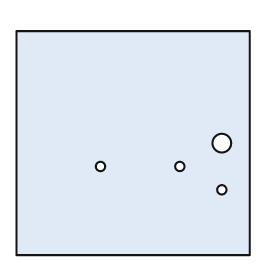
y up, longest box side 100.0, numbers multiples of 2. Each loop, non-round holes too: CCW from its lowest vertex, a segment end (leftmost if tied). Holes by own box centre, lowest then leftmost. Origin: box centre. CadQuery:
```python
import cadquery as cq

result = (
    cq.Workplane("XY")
    .moveTo(-50.0, -48.0)
    .lineTo(50.0, -48.0)
    .lineTo(50.0, 48.0)
    .lineTo(-50.0, 48.0)
    .close()
    .moveTo(38.0, -20.0)
    .circle(2.0)
    .moveTo(-14.0, -10.0)
    .circle(2.0)
    .moveTo(20.0, -10.0)
    .circle(2.0)
    .moveTo(38.0, 0.0)
    .circle(4.0)
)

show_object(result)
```